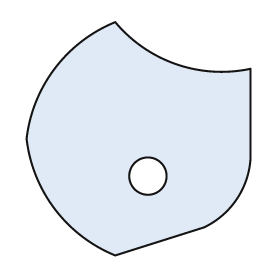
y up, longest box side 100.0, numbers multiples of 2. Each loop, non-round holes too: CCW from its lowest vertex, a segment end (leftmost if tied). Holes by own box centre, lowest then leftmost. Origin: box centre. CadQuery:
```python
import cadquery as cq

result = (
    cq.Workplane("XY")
    .moveTo(-10.0, -50.0)
    .lineTo(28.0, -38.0)
    .threePointArc((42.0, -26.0), (48.0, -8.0))
    .lineTo(48.0, 30.0)
    .threePointArc((16.0, 32.0), (-10.0, 50.0))
    .threePointArc((-36.0, 30.0), (-48.0, 0.0))
    .threePointArc((-36.0, -30.0), (-10.0, -50.0))
    .close()
    .moveTo(4.0, -16.0)
    .circle(8.0)
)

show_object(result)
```